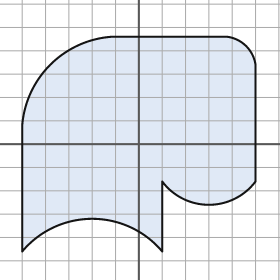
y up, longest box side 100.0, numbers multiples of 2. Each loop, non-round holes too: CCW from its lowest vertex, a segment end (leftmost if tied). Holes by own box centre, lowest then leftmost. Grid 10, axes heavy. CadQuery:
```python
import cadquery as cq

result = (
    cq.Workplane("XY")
    .moveTo(-50.0, -46.0)
    .threePointArc((-20.0, -32.0), (10.0, -46.0))
    .lineTo(10.0, -16.0)
    .threePointArc((30.0, -26.0), (50.0, -16.0))
    .lineTo(50.0, 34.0)
    .threePointArc((46.0, 42.0), (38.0, 46.0))
    .lineTo(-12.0, 46.0)
    .threePointArc((-38.0, 34.0), (-50.0, 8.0))
    .close()
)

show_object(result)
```